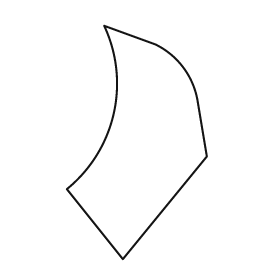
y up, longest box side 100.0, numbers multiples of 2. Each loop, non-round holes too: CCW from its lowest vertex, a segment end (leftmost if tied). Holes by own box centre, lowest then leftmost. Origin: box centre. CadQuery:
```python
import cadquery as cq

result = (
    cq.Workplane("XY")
    .moveTo(-6.0, -50.0)
    .lineTo(30.0, -6.0)
    .lineTo(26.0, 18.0)
    .threePointArc((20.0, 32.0), (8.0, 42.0))
    .lineTo(-14.0, 50.0)
    .threePointArc((-10.0, 12.0), (-30.0, -20.0))
    .close()
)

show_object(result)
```